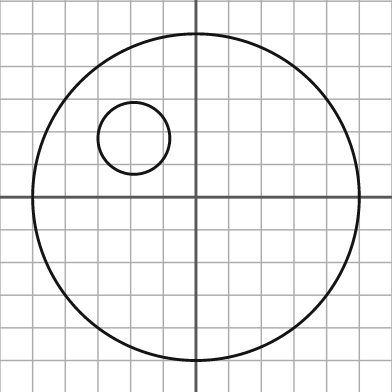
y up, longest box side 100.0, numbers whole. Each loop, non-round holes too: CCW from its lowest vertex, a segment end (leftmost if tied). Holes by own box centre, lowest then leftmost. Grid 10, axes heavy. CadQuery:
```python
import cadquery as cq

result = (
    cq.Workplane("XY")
    .moveTo(0.0, 0.0)
    .circle(50.0)
    .moveTo(-19.0, 18.0)
    .circle(11.0)
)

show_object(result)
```